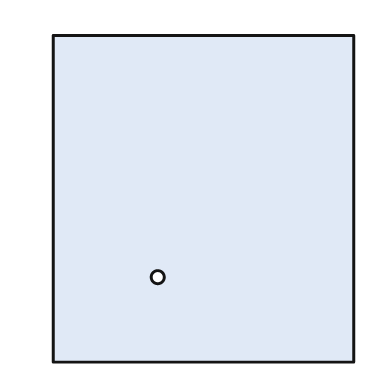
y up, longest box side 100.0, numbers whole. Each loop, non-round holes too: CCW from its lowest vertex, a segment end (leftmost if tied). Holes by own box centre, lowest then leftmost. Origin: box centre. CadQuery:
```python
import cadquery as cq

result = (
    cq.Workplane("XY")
    .moveTo(-46.0, -50.0)
    .lineTo(46.0, -50.0)
    .lineTo(46.0, 50.0)
    .lineTo(-46.0, 50.0)
    .close()
    .moveTo(-14.0, -24.0)
    .circle(2.0)
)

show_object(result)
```